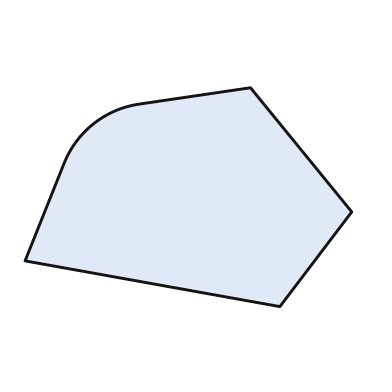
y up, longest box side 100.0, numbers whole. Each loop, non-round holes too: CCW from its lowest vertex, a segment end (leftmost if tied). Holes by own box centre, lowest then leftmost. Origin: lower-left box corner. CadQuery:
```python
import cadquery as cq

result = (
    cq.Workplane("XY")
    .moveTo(78.0, 0.0)
    .lineTo(100.0, 29.0)
    .lineTo(69.0, 67.0)
    .lineTo(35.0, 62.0)
    .threePointArc((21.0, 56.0), (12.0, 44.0))
    .lineTo(0.0, 14.0)
    .close()
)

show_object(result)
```